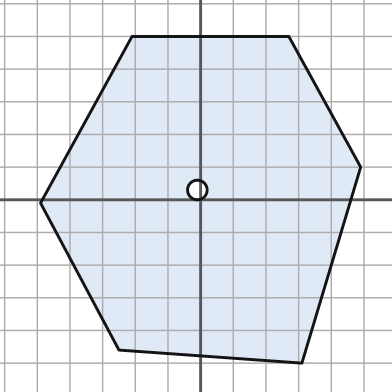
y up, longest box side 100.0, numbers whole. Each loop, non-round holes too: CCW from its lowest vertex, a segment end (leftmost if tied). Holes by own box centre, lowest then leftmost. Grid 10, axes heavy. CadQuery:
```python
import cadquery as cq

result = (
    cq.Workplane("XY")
    .moveTo(31.0, -50.0)
    .lineTo(49.0, 10.0)
    .lineTo(27.0, 50.0)
    .lineTo(-21.0, 50.0)
    .lineTo(-49.0, -1.0)
    .lineTo(-25.0, -46.0)
    .close()
    .moveTo(-1.0, 3.0)
    .circle(3.0)
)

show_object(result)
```